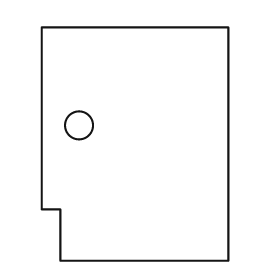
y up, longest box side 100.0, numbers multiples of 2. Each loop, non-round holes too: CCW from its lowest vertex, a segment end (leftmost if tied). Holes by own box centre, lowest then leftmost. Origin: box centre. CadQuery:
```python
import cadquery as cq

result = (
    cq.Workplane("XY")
    .moveTo(-32.0, -50.0)
    .lineTo(40.0, -50.0)
    .lineTo(40.0, 50.0)
    .lineTo(-40.0, 50.0)
    .lineTo(-40.0, -28.0)
    .lineTo(-32.0, -28.0)
    .close()
    .moveTo(-24.0, 8.0)
    .circle(6.0)
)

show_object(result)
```